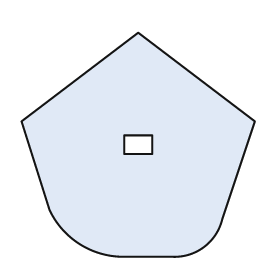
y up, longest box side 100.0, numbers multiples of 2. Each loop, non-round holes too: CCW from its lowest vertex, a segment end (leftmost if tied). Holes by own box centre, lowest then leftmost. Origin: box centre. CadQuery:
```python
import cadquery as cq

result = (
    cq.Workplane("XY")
    .moveTo(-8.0, -48.0)
    .lineTo(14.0, -48.0)
    .threePointArc((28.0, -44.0), (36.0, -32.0))
    .lineTo(50.0, 10.0)
    .lineTo(0.0, 48.0)
    .lineTo(-50.0, 10.0)
    .lineTo(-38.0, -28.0)
    .threePointArc((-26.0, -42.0), (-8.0, -48.0))
    .close()
    .moveTo(-6.0, -4.0)
    .lineTo(6.0, -4.0)
    .lineTo(6.0, 4.0)
    .lineTo(-6.0, 4.0)
    .close()
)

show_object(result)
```